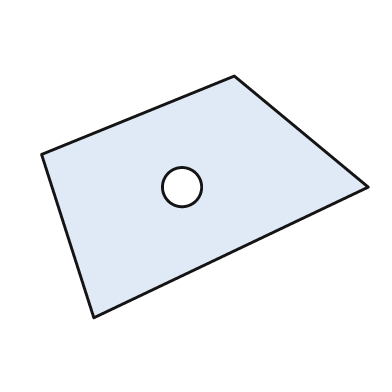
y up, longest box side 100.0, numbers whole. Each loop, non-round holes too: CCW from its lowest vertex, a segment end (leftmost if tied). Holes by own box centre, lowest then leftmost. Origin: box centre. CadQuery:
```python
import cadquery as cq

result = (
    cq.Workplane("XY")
    .moveTo(-34.0, -37.0)
    .lineTo(50.0, 3.0)
    .lineTo(9.0, 37.0)
    .lineTo(-50.0, 13.0)
    .close()
    .moveTo(-7.0, 3.0)
    .circle(6.0)
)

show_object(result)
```